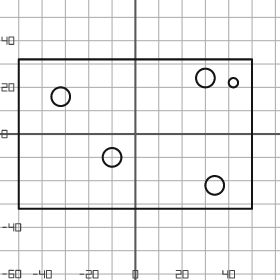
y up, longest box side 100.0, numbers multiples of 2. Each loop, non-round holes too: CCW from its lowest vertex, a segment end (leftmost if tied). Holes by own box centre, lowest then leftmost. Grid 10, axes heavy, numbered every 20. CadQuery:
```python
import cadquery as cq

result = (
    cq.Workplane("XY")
    .moveTo(-50.0, -32.0)
    .lineTo(50.0, -32.0)
    .lineTo(50.0, 32.0)
    .lineTo(-50.0, 32.0)
    .close()
    .moveTo(34.0, -22.0)
    .circle(4.0)
    .moveTo(-10.0, -10.0)
    .circle(4.0)
    .moveTo(-32.0, 16.0)
    .circle(4.0)
    .moveTo(42.0, 22.0)
    .circle(2.0)
    .moveTo(30.0, 24.0)
    .circle(4.0)
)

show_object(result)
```